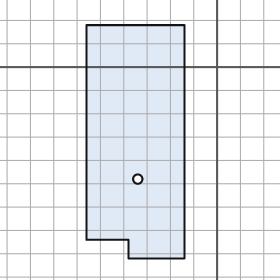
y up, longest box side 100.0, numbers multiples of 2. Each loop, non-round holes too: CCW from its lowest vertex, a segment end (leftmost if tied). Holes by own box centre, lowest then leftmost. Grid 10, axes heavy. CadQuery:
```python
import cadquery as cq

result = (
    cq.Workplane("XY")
    .moveTo(-38.0, -82.0)
    .lineTo(-14.0, -82.0)
    .lineTo(-14.0, 18.0)
    .lineTo(-56.0, 18.0)
    .lineTo(-56.0, -74.0)
    .lineTo(-38.0, -74.0)
    .close()
    .moveTo(-34.0, -48.0)
    .circle(2.0)
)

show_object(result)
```